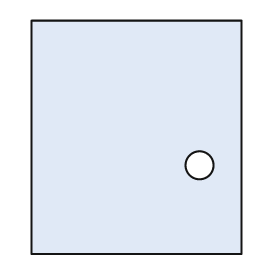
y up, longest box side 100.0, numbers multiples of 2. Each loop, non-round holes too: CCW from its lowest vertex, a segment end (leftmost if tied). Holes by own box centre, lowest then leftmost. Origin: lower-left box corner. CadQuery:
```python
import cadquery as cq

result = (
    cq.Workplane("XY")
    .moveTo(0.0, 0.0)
    .lineTo(90.0, 0.0)
    .lineTo(90.0, 100.0)
    .lineTo(0.0, 100.0)
    .close()
    .moveTo(72.0, 38.0)
    .circle(6.0)
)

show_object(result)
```